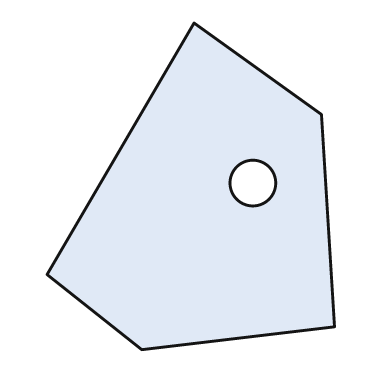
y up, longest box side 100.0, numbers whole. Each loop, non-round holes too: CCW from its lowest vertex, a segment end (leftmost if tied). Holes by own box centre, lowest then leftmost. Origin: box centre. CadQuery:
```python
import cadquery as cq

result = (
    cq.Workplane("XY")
    .moveTo(-15.0, -50.0)
    .lineTo(44.0, -43.0)
    .lineTo(40.0, 22.0)
    .lineTo(1.0, 50.0)
    .lineTo(-44.0, -27.0)
    .close()
    .moveTo(19.0, 1.0)
    .circle(7.0)
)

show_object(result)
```